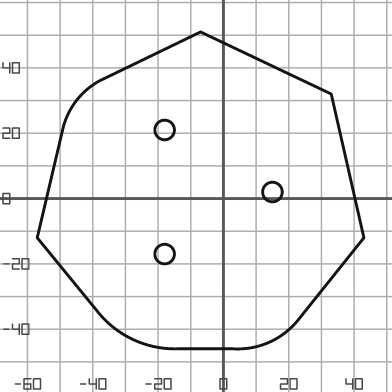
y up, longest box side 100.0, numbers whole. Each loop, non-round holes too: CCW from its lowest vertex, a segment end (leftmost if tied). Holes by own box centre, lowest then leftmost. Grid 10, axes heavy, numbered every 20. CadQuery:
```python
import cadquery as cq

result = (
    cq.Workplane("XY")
    .moveTo(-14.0, -46.0)
    .lineTo(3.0, -46.0)
    .threePointArc((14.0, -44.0), (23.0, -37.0))
    .lineTo(43.0, -12.0)
    .lineTo(33.0, 32.0)
    .lineTo(-7.0, 51.0)
    .lineTo(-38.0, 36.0)
    .threePointArc((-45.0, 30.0), (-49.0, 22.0))
    .lineTo(-57.0, -12.0)
    .lineTo(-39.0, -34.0)
    .threePointArc((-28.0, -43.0), (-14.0, -46.0))
    .close()
    .moveTo(-18.0, -17.0)
    .circle(3.0)
    .moveTo(15.0, 2.0)
    .circle(3.0)
    .moveTo(-18.0, 21.0)
    .circle(3.0)
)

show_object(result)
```